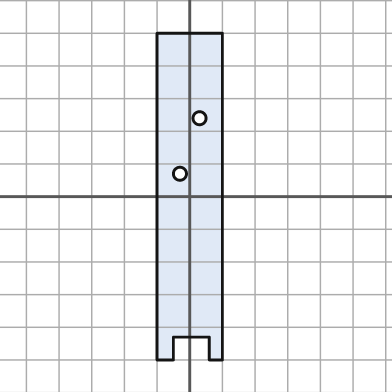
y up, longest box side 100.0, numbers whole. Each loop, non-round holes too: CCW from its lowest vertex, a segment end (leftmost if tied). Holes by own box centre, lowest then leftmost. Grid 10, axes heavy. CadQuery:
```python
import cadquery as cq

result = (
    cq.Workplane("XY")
    .moveTo(-10.0, -50.0)
    .lineTo(-5.0, -50.0)
    .lineTo(-5.0, -43.0)
    .lineTo(6.0, -43.0)
    .lineTo(6.0, -50.0)
    .lineTo(10.0, -50.0)
    .lineTo(10.0, 50.0)
    .lineTo(-10.0, 50.0)
    .close()
    .moveTo(-3.0, 7.0)
    .circle(2.0)
    .moveTo(3.0, 24.0)
    .circle(2.0)
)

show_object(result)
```